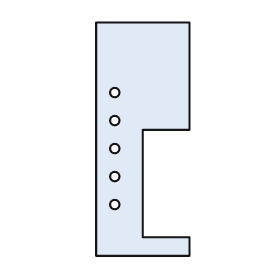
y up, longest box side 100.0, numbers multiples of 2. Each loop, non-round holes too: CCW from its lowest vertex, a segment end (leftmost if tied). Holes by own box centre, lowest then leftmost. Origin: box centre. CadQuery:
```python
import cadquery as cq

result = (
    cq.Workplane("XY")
    .moveTo(-20.0, -50.0)
    .lineTo(20.0, -50.0)
    .lineTo(20.0, -42.0)
    .lineTo(0.0, -42.0)
    .lineTo(0.0, 4.0)
    .lineTo(20.0, 4.0)
    .lineTo(20.0, 50.0)
    .lineTo(-20.0, 50.0)
    .close()
    .moveTo(-12.0, -28.0)
    .circle(2.0)
    .moveTo(-12.0, -16.0)
    .circle(2.0)
    .moveTo(-12.0, -4.0)
    .circle(2.0)
    .moveTo(-12.0, 8.0)
    .circle(2.0)
    .moveTo(-12.0, 20.0)
    .circle(2.0)
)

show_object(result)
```